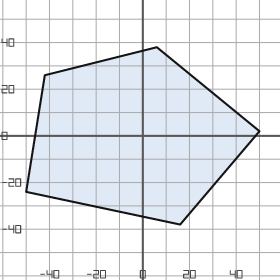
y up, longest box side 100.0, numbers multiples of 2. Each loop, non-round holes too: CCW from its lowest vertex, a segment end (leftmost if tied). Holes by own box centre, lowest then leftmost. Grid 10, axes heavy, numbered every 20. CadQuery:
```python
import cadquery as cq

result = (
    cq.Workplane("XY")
    .moveTo(16.0, -38.0)
    .lineTo(50.0, 2.0)
    .lineTo(6.0, 38.0)
    .lineTo(-42.0, 26.0)
    .lineTo(-50.0, -24.0)
    .close()
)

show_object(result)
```